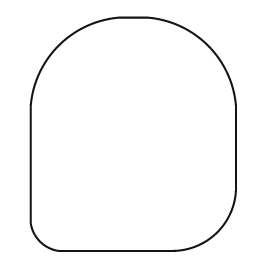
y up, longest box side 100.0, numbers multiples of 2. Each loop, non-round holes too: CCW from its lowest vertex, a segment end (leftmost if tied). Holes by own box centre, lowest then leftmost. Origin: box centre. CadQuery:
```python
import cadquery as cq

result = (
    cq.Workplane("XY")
    .moveTo(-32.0, -50.0)
    .lineTo(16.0, -50.0)
    .threePointArc((36.0, -42.0), (44.0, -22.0))
    .lineTo(44.0, 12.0)
    .threePointArc((32.0, 38.0), (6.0, 50.0))
    .lineTo(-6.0, 50.0)
    .threePointArc((-32.0, 38.0), (-44.0, 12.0))
    .lineTo(-44.0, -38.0)
    .threePointArc((-40.0, -46.0), (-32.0, -50.0))
    .close()
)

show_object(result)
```